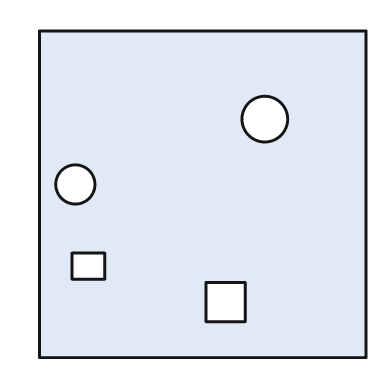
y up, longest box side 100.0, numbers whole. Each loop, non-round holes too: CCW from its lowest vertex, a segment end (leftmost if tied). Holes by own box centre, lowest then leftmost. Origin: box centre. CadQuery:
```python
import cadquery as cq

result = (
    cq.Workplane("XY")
    .moveTo(-50.0, -50.0)
    .lineTo(50.0, -50.0)
    .lineTo(50.0, 50.0)
    .lineTo(-50.0, 50.0)
    .close()
    .moveTo(1.0, -39.0)
    .lineTo(13.0, -39.0)
    .lineTo(13.0, -27.0)
    .lineTo(1.0, -27.0)
    .close()
    .moveTo(-40.0, -26.0)
    .lineTo(-30.0, -26.0)
    .lineTo(-30.0, -18.0)
    .lineTo(-40.0, -18.0)
    .close()
    .moveTo(-39.0, 3.0)
    .circle(6.0)
    .moveTo(19.0, 23.0)
    .circle(7.0)
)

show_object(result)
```